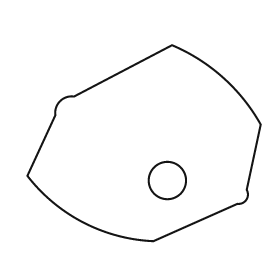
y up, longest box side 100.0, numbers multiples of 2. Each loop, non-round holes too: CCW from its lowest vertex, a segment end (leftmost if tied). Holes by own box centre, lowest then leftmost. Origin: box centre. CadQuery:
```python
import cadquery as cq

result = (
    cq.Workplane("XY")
    .moveTo(4.0, -42.0)
    .lineTo(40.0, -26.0)
    .threePointArc((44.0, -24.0), (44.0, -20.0))
    .lineTo(50.0, 8.0)
    .threePointArc((34.0, 28.0), (12.0, 42.0))
    .lineTo(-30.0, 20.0)
    .threePointArc((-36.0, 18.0), (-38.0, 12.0))
    .lineTo(-50.0, -14.0)
    .threePointArc((-26.0, -34.0), (4.0, -42.0))
    .close()
    .moveTo(10.0, -16.0)
    .circle(8.0)
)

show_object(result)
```